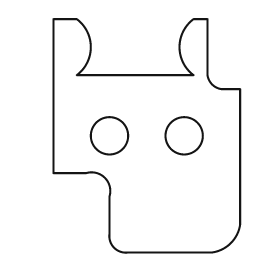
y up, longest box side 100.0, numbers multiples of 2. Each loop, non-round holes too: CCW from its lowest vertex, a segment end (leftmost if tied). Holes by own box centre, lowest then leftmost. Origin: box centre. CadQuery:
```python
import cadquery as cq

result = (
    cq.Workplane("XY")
    .moveTo(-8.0, -50.0)
    .lineTo(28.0, -50.0)
    .threePointArc((36.0, -46.0), (40.0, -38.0))
    .lineTo(40.0, 20.0)
    .lineTo(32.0, 20.0)
    .threePointArc((28.0, 22.0), (26.0, 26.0))
    .lineTo(26.0, 50.0)
    .lineTo(20.0, 50.0)
    .threePointArc((14.0, 38.0), (20.0, 26.0))
    .lineTo(-30.0, 26.0)
    .threePointArc((-24.0, 38.0), (-30.0, 50.0))
    .lineTo(-40.0, 50.0)
    .lineTo(-40.0, -16.0)
    .lineTo(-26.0, -16.0)
    .threePointArc((-18.0, -18.0), (-16.0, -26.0))
    .lineTo(-16.0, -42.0)
    .threePointArc((-14.0, -48.0), (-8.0, -50.0))
    .close()
    .moveTo(-16.0, 0.0)
    .circle(8.0)
    .moveTo(16.0, 0.0)
    .circle(8.0)
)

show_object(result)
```